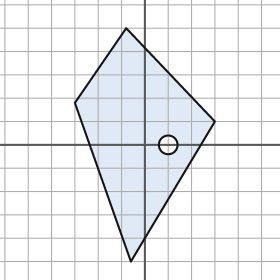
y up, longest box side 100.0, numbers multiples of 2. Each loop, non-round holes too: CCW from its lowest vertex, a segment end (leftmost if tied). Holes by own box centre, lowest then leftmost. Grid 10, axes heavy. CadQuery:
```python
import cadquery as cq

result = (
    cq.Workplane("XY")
    .moveTo(-6.0, -50.0)
    .lineTo(30.0, 10.0)
    .lineTo(-8.0, 50.0)
    .lineTo(-30.0, 18.0)
    .close()
    .moveTo(10.0, 0.0)
    .circle(4.0)
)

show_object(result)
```